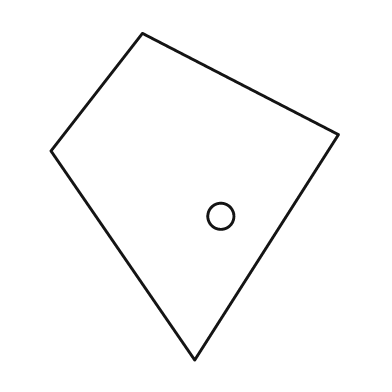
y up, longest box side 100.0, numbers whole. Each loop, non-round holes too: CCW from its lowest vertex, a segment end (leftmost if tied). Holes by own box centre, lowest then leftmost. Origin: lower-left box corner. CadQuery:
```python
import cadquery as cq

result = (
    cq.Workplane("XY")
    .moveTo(44.0, 0.0)
    .lineTo(88.0, 69.0)
    .lineTo(28.0, 100.0)
    .lineTo(0.0, 64.0)
    .close()
    .moveTo(52.0, 44.0)
    .circle(4.0)
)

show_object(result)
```